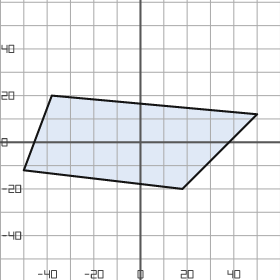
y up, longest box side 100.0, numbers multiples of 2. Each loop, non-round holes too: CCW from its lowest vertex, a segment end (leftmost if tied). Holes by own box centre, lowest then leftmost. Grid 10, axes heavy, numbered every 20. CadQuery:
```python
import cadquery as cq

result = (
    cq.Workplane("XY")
    .moveTo(18.0, -20.0)
    .lineTo(50.0, 12.0)
    .lineTo(-38.0, 20.0)
    .lineTo(-50.0, -12.0)
    .close()
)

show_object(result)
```